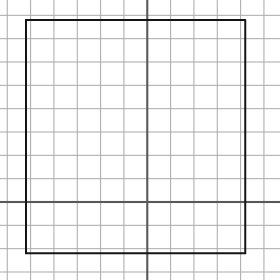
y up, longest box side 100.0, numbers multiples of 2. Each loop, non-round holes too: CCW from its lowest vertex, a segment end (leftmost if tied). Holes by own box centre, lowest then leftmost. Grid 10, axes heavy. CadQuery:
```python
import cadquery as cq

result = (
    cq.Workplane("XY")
    .moveTo(-52.0, -22.0)
    .lineTo(42.0, -22.0)
    .lineTo(42.0, 78.0)
    .lineTo(-52.0, 78.0)
    .close()
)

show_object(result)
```